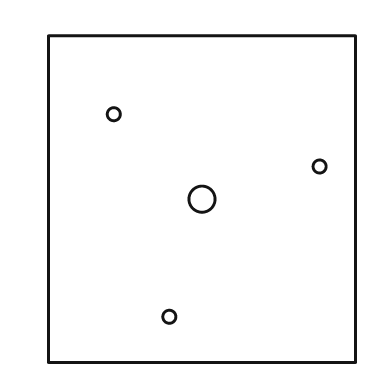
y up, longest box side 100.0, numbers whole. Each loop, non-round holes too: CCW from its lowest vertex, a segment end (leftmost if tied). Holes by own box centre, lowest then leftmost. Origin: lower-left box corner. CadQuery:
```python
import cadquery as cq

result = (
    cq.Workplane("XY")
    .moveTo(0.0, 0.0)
    .lineTo(94.0, 0.0)
    .lineTo(94.0, 100.0)
    .lineTo(0.0, 100.0)
    .close()
    .moveTo(37.0, 14.0)
    .circle(2.0)
    .moveTo(47.0, 50.0)
    .circle(4.0)
    .moveTo(83.0, 60.0)
    .circle(2.0)
    .moveTo(20.0, 76.0)
    .circle(2.0)
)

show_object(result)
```